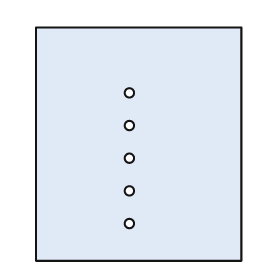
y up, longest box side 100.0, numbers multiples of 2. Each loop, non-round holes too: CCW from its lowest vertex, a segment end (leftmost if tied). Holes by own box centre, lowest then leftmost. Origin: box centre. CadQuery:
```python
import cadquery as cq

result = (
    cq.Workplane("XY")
    .moveTo(-44.0, -50.0)
    .lineTo(44.0, -50.0)
    .lineTo(44.0, 50.0)
    .lineTo(-44.0, 50.0)
    .close()
    .moveTo(-4.0, -34.0)
    .circle(2.0)
    .moveTo(-4.0, -20.0)
    .circle(2.0)
    .moveTo(-4.0, -6.0)
    .circle(2.0)
    .moveTo(-4.0, 8.0)
    .circle(2.0)
    .moveTo(-4.0, 22.0)
    .circle(2.0)
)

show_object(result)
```